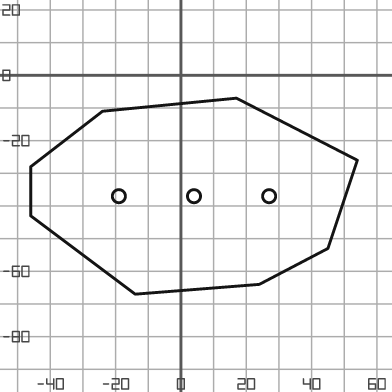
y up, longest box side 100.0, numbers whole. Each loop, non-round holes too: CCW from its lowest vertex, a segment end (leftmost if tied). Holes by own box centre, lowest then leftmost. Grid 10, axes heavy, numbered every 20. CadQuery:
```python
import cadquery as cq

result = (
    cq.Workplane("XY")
    .moveTo(-14.0, -67.0)
    .lineTo(24.0, -64.0)
    .lineTo(45.0, -53.0)
    .lineTo(54.0, -26.0)
    .lineTo(17.0, -7.0)
    .lineTo(-24.0, -11.0)
    .lineTo(-46.0, -28.0)
    .lineTo(-46.0, -43.0)
    .close()
    .moveTo(-19.0, -37.0)
    .circle(2.0)
    .moveTo(4.0, -37.0)
    .circle(2.0)
    .moveTo(27.0, -37.0)
    .circle(2.0)
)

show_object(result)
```